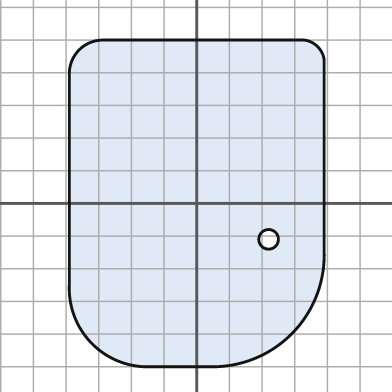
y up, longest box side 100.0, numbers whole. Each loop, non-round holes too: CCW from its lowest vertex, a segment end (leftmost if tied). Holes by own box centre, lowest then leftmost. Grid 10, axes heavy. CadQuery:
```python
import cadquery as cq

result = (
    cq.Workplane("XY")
    .moveTo(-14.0, -50.0)
    .lineTo(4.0, -50.0)
    .threePointArc((29.0, -40.0), (39.0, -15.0))
    .lineTo(39.0, 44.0)
    .threePointArc((37.0, 48.0), (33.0, 50.0))
    .lineTo(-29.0, 50.0)
    .threePointArc((-36.0, 47.0), (-39.0, 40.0))
    .lineTo(-39.0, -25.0)
    .threePointArc((-32.0, -43.0), (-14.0, -50.0))
    .close()
    .moveTo(22.0, -11.0)
    .circle(3.0)
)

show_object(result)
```